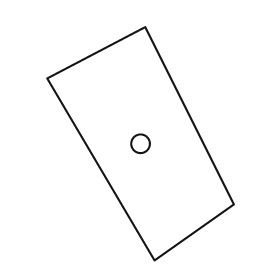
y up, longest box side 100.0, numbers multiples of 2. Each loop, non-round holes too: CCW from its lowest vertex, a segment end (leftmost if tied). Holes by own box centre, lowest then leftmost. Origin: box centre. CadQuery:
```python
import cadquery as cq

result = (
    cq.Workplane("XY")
    .moveTo(6.0, -50.0)
    .lineTo(40.0, -26.0)
    .lineTo(2.0, 50.0)
    .lineTo(-40.0, 28.0)
    .close()
    .moveTo(0.0, 0.0)
    .circle(4.0)
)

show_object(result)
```